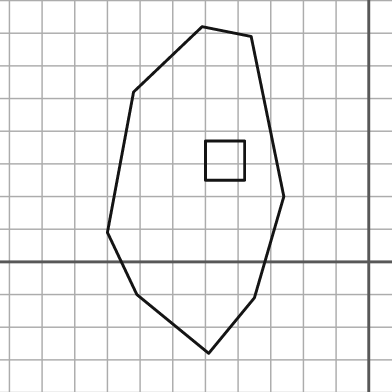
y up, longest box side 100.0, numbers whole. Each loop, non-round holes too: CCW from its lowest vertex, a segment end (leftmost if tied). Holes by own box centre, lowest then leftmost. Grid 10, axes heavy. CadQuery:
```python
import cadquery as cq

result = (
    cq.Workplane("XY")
    .moveTo(-49.0, -28.0)
    .lineTo(-35.0, -11.0)
    .lineTo(-26.0, 20.0)
    .lineTo(-36.0, 69.0)
    .lineTo(-51.0, 72.0)
    .lineTo(-72.0, 52.0)
    .lineTo(-80.0, 9.0)
    .lineTo(-71.0, -10.0)
    .close()
    .moveTo(-50.0, 25.0)
    .lineTo(-38.0, 25.0)
    .lineTo(-38.0, 37.0)
    .lineTo(-50.0, 37.0)
    .close()
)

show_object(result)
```